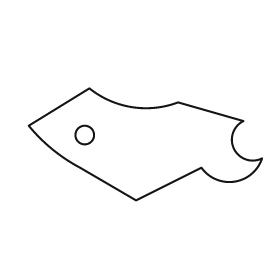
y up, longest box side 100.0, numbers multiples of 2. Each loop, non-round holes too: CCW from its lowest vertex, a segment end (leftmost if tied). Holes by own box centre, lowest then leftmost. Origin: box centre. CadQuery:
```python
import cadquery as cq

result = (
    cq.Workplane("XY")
    .moveTo(-4.0, -24.0)
    .lineTo(24.0, -10.0)
    .threePointArc((38.0, -16.0), (50.0, -6.0))
    .threePointArc((38.0, -2.0), (42.0, 10.0))
    .lineTo(14.0, 18.0)
    .threePointArc((-6.0, 16.0), (-24.0, 24.0))
    .lineTo(-50.0, 8.0)
    .threePointArc((-40.0, -2.0), (-28.0, -10.0))
    .close()
    .moveTo(-26.0, 4.0)
    .circle(4.0)
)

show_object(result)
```